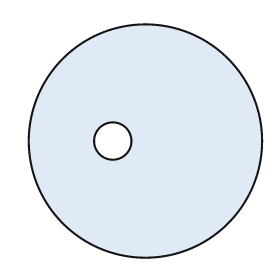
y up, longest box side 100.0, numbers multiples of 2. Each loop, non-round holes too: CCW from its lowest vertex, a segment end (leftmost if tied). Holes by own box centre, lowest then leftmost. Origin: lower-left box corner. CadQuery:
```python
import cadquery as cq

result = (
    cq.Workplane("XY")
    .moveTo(50.0, 50.0)
    .circle(50.0)
    .moveTo(36.0, 50.0)
    .circle(8.0)
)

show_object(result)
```